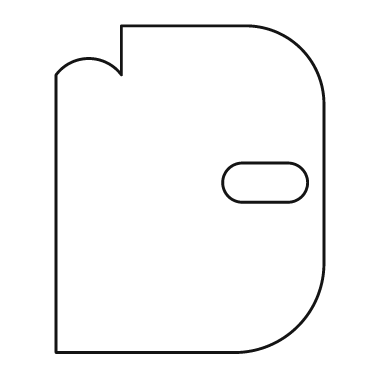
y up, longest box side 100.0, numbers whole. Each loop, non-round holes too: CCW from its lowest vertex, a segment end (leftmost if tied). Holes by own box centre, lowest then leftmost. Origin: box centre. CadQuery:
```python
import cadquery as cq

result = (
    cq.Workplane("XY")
    .moveTo(-41.0, -50.0)
    .lineTo(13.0, -50.0)
    .threePointArc((33.0, -42.0), (41.0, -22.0))
    .lineTo(41.0, 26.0)
    .threePointArc((34.0, 43.0), (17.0, 50.0))
    .lineTo(-21.0, 50.0)
    .lineTo(-21.0, 35.0)
    .threePointArc((-31.0, 40.0), (-41.0, 35.0))
    .close()
    .moveTo(16.0, -4.0)
    .lineTo(30.0, -4.0)
    .threePointArc((36.0, 2.0), (30.0, 8.0))
    .lineTo(16.0, 8.0)
    .threePointArc((10.0, 2.0), (16.0, -4.0))
    .close()
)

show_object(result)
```